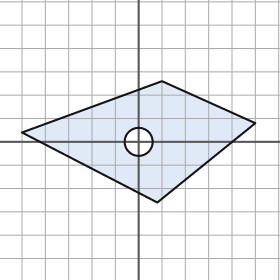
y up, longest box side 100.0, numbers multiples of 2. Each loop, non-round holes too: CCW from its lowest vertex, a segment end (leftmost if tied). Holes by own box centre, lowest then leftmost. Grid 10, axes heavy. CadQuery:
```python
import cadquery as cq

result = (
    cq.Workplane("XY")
    .moveTo(8.0, -26.0)
    .lineTo(50.0, 8.0)
    .lineTo(10.0, 26.0)
    .lineTo(-50.0, 4.0)
    .close()
    .moveTo(0.0, 0.0)
    .circle(6.0)
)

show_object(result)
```